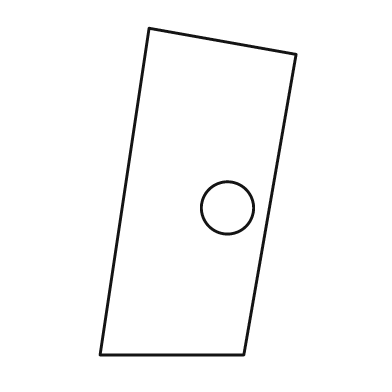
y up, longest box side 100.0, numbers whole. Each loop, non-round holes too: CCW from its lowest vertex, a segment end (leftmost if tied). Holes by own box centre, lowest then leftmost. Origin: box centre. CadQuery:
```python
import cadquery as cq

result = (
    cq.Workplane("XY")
    .moveTo(-30.0, -50.0)
    .lineTo(14.0, -50.0)
    .lineTo(30.0, 42.0)
    .lineTo(-15.0, 50.0)
    .close()
    .moveTo(9.0, -5.0)
    .circle(8.0)
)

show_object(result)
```